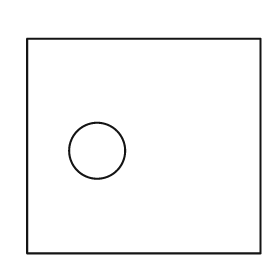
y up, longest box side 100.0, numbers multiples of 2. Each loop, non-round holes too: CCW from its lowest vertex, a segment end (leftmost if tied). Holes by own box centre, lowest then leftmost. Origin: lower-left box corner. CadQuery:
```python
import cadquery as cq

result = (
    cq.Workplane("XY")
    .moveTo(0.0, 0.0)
    .lineTo(100.0, 0.0)
    .lineTo(100.0, 92.0)
    .lineTo(0.0, 92.0)
    .close()
    .moveTo(30.0, 44.0)
    .circle(12.0)
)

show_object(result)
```